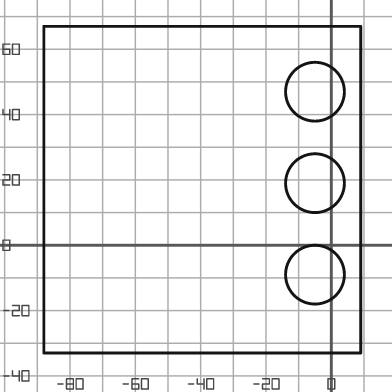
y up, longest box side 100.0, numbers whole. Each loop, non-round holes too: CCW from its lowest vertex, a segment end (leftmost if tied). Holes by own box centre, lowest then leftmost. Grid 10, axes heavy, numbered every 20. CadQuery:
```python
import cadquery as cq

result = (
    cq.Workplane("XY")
    .moveTo(-88.0, -33.0)
    .lineTo(9.0, -33.0)
    .lineTo(9.0, 67.0)
    .lineTo(-88.0, 67.0)
    .close()
    .moveTo(-5.0, -9.0)
    .circle(9.0)
    .moveTo(-5.0, 19.0)
    .circle(9.0)
    .moveTo(-5.0, 47.0)
    .circle(9.0)
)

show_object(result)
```